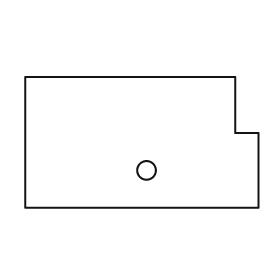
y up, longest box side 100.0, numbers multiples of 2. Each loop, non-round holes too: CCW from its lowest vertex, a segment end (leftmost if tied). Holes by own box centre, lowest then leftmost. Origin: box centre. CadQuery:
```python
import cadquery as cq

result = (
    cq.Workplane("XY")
    .moveTo(-50.0, -28.0)
    .lineTo(50.0, -28.0)
    .lineTo(50.0, 4.0)
    .lineTo(40.0, 4.0)
    .lineTo(40.0, 28.0)
    .lineTo(-50.0, 28.0)
    .close()
    .moveTo(2.0, -12.0)
    .circle(4.0)
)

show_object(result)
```